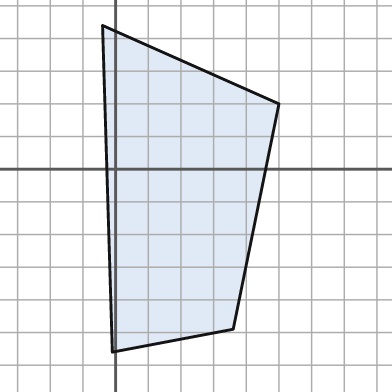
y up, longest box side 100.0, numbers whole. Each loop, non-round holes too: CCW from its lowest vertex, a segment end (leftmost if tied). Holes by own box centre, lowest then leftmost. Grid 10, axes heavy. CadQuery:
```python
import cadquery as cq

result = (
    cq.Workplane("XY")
    .moveTo(-1.0, -56.0)
    .lineTo(36.0, -49.0)
    .lineTo(50.0, 20.0)
    .lineTo(-4.0, 44.0)
    .close()
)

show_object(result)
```